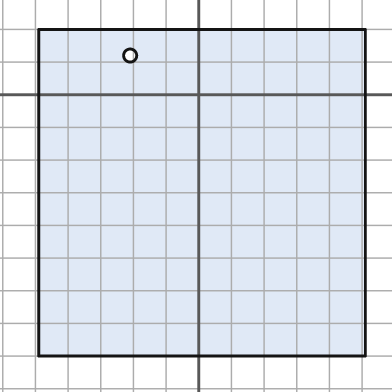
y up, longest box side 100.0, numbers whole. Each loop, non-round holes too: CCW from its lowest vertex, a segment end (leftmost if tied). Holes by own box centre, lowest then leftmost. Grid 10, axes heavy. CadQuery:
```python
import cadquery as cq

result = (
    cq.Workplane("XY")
    .moveTo(-49.0, -80.0)
    .lineTo(51.0, -80.0)
    .lineTo(51.0, 20.0)
    .lineTo(-49.0, 20.0)
    .close()
    .moveTo(-21.0, 12.0)
    .circle(2.0)
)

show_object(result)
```